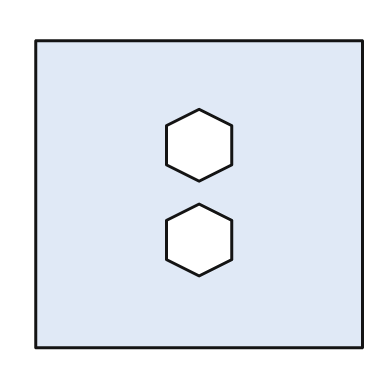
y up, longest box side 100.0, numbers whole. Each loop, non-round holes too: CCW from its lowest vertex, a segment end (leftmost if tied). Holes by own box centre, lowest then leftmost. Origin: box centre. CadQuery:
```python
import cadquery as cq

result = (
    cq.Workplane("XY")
    .moveTo(-50.0, -47.0)
    .lineTo(50.0, -47.0)
    .lineTo(50.0, 47.0)
    .lineTo(-50.0, 47.0)
    .close()
    .moveTo(0.0, -25.0)
    .lineTo(10.0, -20.0)
    .lineTo(10.0, -8.0)
    .lineTo(0.0, -3.0)
    .lineTo(-10.0, -8.0)
    .lineTo(-10.0, -20.0)
    .close()
    .moveTo(0.0, 4.0)
    .lineTo(10.0, 9.0)
    .lineTo(10.0, 21.0)
    .lineTo(0.0, 26.0)
    .lineTo(-10.0, 21.0)
    .lineTo(-10.0, 9.0)
    .close()
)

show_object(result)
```